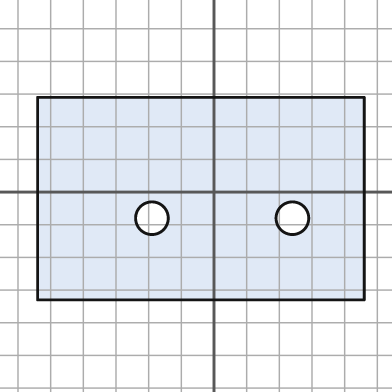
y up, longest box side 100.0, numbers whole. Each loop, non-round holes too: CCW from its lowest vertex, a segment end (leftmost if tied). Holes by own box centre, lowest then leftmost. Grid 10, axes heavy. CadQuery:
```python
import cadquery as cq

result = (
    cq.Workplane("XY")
    .moveTo(-54.0, -33.0)
    .lineTo(46.0, -33.0)
    .lineTo(46.0, 29.0)
    .lineTo(-54.0, 29.0)
    .close()
    .moveTo(-19.0, -8.0)
    .circle(5.0)
    .moveTo(24.0, -8.0)
    .circle(5.0)
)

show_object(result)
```